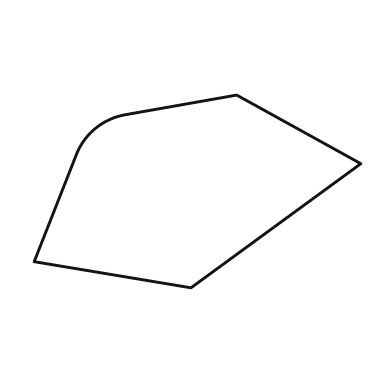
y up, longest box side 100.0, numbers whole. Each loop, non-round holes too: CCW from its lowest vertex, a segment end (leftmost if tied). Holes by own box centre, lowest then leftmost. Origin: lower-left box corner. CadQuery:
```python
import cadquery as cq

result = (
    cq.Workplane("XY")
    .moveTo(48.0, 0.0)
    .lineTo(100.0, 38.0)
    .lineTo(62.0, 59.0)
    .lineTo(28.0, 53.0)
    .threePointArc((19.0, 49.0), (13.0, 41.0))
    .lineTo(0.0, 8.0)
    .close()
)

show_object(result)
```